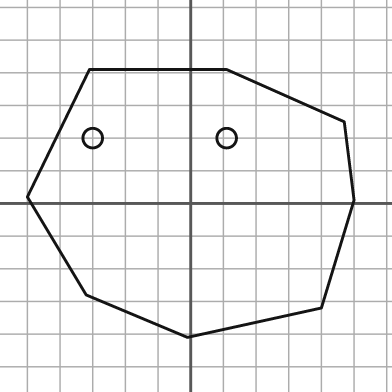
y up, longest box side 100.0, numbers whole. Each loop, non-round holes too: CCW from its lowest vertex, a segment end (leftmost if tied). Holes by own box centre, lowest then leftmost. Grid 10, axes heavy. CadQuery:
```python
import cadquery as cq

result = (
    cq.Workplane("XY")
    .moveTo(-1.0, -41.0)
    .lineTo(40.0, -32.0)
    .lineTo(50.0, 1.0)
    .lineTo(47.0, 25.0)
    .lineTo(11.0, 41.0)
    .lineTo(-31.0, 41.0)
    .lineTo(-50.0, 2.0)
    .lineTo(-32.0, -28.0)
    .close()
    .moveTo(-30.0, 20.0)
    .circle(3.0)
    .moveTo(11.0, 20.0)
    .circle(3.0)
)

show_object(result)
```